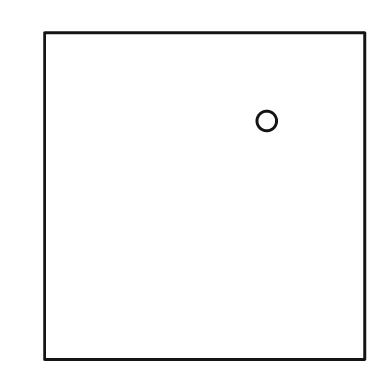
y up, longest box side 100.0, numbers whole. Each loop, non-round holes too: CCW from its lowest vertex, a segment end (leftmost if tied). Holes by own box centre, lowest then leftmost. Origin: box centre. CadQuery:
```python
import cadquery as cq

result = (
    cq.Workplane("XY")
    .moveTo(-49.0, -50.0)
    .lineTo(49.0, -50.0)
    .lineTo(49.0, 50.0)
    .lineTo(-49.0, 50.0)
    .close()
    .moveTo(19.0, 23.0)
    .circle(3.0)
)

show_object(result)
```